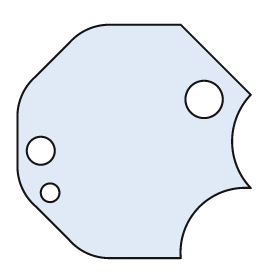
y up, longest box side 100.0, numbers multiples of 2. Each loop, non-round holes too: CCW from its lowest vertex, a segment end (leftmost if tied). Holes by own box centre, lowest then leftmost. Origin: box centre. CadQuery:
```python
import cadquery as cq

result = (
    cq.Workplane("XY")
    .moveTo(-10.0, -50.0)
    .lineTo(20.0, -50.0)
    .threePointArc((28.0, -28.0), (50.0, -20.0))
    .threePointArc((42.0, 0.0), (50.0, 20.0))
    .lineTo(20.0, 50.0)
    .lineTo(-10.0, 50.0)
    .threePointArc((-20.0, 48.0), (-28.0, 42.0))
    .lineTo(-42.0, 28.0)
    .threePointArc((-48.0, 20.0), (-50.0, 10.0))
    .lineTo(-50.0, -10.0)
    .threePointArc((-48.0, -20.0), (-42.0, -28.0))
    .lineTo(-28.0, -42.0)
    .threePointArc((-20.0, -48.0), (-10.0, -50.0))
    .close()
    .moveTo(-36.0, -22.0)
    .circle(4.0)
    .moveTo(-40.0, -4.0)
    .circle(6.0)
    .moveTo(30.0, 18.0)
    .circle(8.0)
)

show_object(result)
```